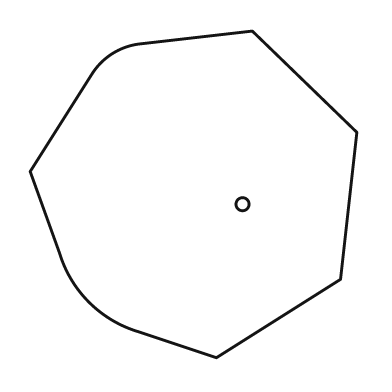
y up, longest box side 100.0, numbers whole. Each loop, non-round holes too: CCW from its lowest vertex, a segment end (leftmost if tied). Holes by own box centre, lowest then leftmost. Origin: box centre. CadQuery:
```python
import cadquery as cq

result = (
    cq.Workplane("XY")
    .moveTo(7.0, -50.0)
    .lineTo(45.0, -26.0)
    .lineTo(50.0, 19.0)
    .lineTo(18.0, 50.0)
    .lineTo(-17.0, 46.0)
    .threePointArc((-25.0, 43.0), (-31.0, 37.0))
    .lineTo(-50.0, 7.0)
    .lineTo(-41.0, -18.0)
    .threePointArc((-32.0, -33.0), (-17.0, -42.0))
    .close()
    .moveTo(15.0, -3.0)
    .circle(2.0)
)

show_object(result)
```